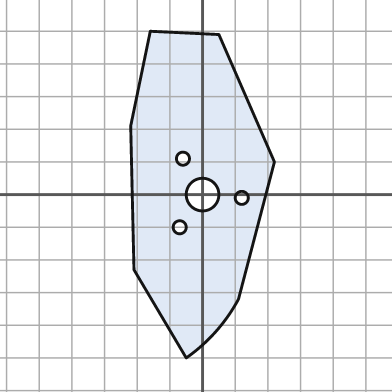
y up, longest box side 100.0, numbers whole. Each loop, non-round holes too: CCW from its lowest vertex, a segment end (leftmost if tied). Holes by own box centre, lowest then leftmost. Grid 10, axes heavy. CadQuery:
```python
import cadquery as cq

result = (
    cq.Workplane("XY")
    .moveTo(-5.0, -50.0)
    .threePointArc((4.0, -42.0), (11.0, -32.0))
    .lineTo(22.0, 10.0)
    .lineTo(5.0, 49.0)
    .lineTo(-16.0, 50.0)
    .lineTo(-22.0, 21.0)
    .lineTo(-21.0, -23.0)
    .close()
    .moveTo(-7.0, -10.0)
    .circle(2.0)
    .moveTo(12.0, -1.0)
    .circle(2.0)
    .moveTo(0.0, 0.0)
    .circle(5.0)
    .moveTo(-6.0, 11.0)
    .circle(2.0)
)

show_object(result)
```